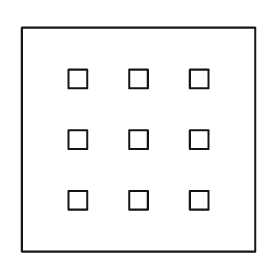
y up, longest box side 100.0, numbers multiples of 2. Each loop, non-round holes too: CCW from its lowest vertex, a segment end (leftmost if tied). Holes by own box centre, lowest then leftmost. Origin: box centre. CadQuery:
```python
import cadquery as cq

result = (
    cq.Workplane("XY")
    .moveTo(-50.0, -48.0)
    .lineTo(50.0, -48.0)
    .lineTo(50.0, 48.0)
    .lineTo(-50.0, 48.0)
    .close()
    .moveTo(-30.0, -30.0)
    .lineTo(-22.0, -30.0)
    .lineTo(-22.0, -22.0)
    .lineTo(-30.0, -22.0)
    .close()
    .moveTo(-4.0, -30.0)
    .lineTo(4.0, -30.0)
    .lineTo(4.0, -22.0)
    .lineTo(-4.0, -22.0)
    .close()
    .moveTo(22.0, -30.0)
    .lineTo(30.0, -30.0)
    .lineTo(30.0, -22.0)
    .lineTo(22.0, -22.0)
    .close()
    .moveTo(-30.0, -4.0)
    .lineTo(-22.0, -4.0)
    .lineTo(-22.0, 4.0)
    .lineTo(-30.0, 4.0)
    .close()
    .moveTo(-4.0, -4.0)
    .lineTo(4.0, -4.0)
    .lineTo(4.0, 4.0)
    .lineTo(-4.0, 4.0)
    .close()
    .moveTo(22.0, -4.0)
    .lineTo(30.0, -4.0)
    .lineTo(30.0, 4.0)
    .lineTo(22.0, 4.0)
    .close()
    .moveTo(-30.0, 22.0)
    .lineTo(-22.0, 22.0)
    .lineTo(-22.0, 30.0)
    .lineTo(-30.0, 30.0)
    .close()
    .moveTo(-4.0, 22.0)
    .lineTo(4.0, 22.0)
    .lineTo(4.0, 30.0)
    .lineTo(-4.0, 30.0)
    .close()
    .moveTo(22.0, 22.0)
    .lineTo(30.0, 22.0)
    .lineTo(30.0, 30.0)
    .lineTo(22.0, 30.0)
    .close()
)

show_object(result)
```